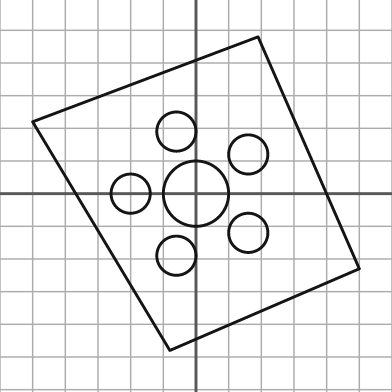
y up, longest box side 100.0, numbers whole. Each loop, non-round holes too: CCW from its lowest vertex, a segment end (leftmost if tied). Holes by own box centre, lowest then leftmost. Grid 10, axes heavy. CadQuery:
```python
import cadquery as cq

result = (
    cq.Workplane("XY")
    .moveTo(-8.0, -48.0)
    .lineTo(50.0, -23.0)
    .lineTo(19.0, 48.0)
    .lineTo(-50.0, 22.0)
    .close()
    .moveTo(-6.0, -19.0)
    .circle(6.0)
    .moveTo(16.0, -12.0)
    .circle(6.0)
    .moveTo(-20.0, 0.0)
    .circle(6.0)
    .moveTo(0.0, 0.0)
    .circle(10.0)
    .moveTo(16.0, 12.0)
    .circle(6.0)
    .moveTo(-6.0, 19.0)
    .circle(6.0)
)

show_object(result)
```